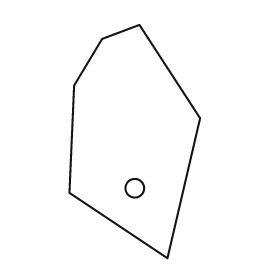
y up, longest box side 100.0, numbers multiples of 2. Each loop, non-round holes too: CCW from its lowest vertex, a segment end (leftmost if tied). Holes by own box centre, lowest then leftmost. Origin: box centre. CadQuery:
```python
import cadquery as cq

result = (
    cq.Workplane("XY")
    .moveTo(14.0, -50.0)
    .lineTo(28.0, 10.0)
    .lineTo(2.0, 50.0)
    .lineTo(-14.0, 44.0)
    .lineTo(-26.0, 24.0)
    .lineTo(-28.0, -22.0)
    .close()
    .moveTo(0.0, -20.0)
    .circle(4.0)
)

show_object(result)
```